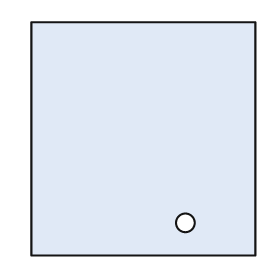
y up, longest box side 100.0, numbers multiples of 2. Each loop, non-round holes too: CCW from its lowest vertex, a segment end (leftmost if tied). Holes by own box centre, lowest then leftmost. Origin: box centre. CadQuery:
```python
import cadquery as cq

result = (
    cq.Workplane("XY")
    .moveTo(-48.0, -50.0)
    .lineTo(48.0, -50.0)
    .lineTo(48.0, 50.0)
    .lineTo(-48.0, 50.0)
    .close()
    .moveTo(18.0, -36.0)
    .circle(4.0)
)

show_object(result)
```